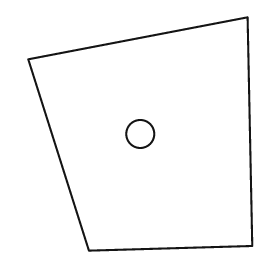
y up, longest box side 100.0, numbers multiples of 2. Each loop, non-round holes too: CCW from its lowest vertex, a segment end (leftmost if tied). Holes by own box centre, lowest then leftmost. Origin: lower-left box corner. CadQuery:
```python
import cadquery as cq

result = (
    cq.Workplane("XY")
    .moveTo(26.0, 0.0)
    .lineTo(96.0, 2.0)
    .lineTo(94.0, 100.0)
    .lineTo(0.0, 82.0)
    .close()
    .moveTo(48.0, 50.0)
    .circle(6.0)
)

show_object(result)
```